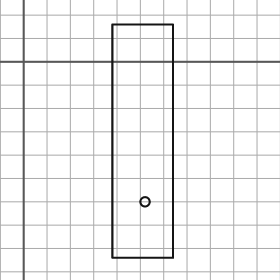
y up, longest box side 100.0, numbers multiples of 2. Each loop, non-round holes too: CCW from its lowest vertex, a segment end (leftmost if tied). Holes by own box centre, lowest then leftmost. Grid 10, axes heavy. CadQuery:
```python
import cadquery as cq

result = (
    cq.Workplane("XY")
    .moveTo(38.0, -84.0)
    .lineTo(64.0, -84.0)
    .lineTo(64.0, 16.0)
    .lineTo(38.0, 16.0)
    .close()
    .moveTo(52.0, -60.0)
    .circle(2.0)
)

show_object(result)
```